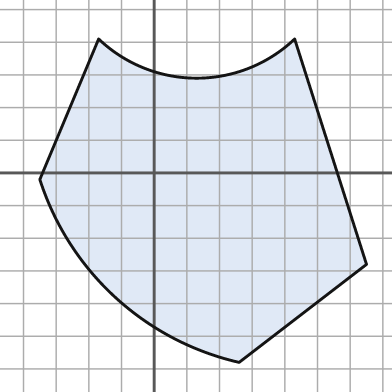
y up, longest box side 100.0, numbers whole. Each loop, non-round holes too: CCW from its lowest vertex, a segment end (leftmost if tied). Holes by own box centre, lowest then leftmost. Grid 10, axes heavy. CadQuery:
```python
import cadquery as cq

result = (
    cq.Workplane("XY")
    .moveTo(26.0, -58.0)
    .lineTo(65.0, -28.0)
    .lineTo(43.0, 41.0)
    .threePointArc((13.0, 29.0), (-17.0, 41.0))
    .lineTo(-35.0, -2.0)
    .threePointArc((-12.0, -38.0), (26.0, -58.0))
    .close()
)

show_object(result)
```